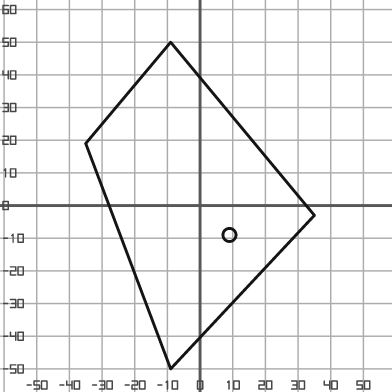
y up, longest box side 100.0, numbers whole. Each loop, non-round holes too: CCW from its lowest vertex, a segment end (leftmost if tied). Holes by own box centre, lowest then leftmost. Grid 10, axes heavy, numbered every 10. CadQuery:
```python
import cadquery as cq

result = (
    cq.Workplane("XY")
    .moveTo(-9.0, -50.0)
    .lineTo(35.0, -3.0)
    .lineTo(-9.0, 50.0)
    .lineTo(-35.0, 19.0)
    .close()
    .moveTo(9.0, -9.0)
    .circle(2.0)
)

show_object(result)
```